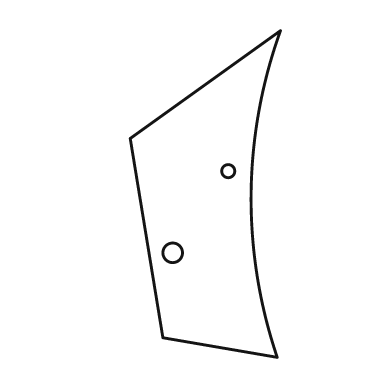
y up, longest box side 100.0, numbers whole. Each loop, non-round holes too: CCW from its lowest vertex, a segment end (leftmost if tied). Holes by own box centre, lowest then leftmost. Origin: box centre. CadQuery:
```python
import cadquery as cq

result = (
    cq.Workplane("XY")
    .moveTo(22.0, -50.0)
    .threePointArc((14.0, 0.0), (23.0, 50.0))
    .lineTo(-23.0, 17.0)
    .lineTo(-13.0, -44.0)
    .close()
    .moveTo(-10.0, -18.0)
    .circle(3.0)
    .moveTo(7.0, 7.0)
    .circle(2.0)
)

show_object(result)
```